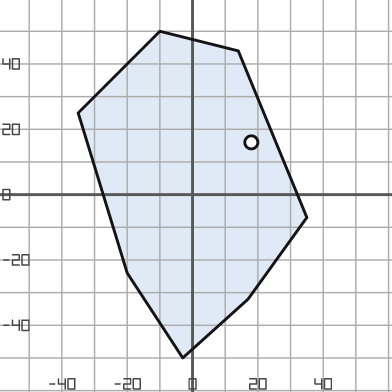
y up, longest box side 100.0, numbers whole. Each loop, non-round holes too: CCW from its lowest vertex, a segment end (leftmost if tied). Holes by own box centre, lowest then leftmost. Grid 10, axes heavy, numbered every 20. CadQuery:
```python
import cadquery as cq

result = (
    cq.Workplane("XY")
    .moveTo(-3.0, -50.0)
    .lineTo(17.0, -32.0)
    .lineTo(35.0, -7.0)
    .lineTo(14.0, 44.0)
    .lineTo(-10.0, 50.0)
    .lineTo(-35.0, 25.0)
    .lineTo(-20.0, -24.0)
    .close()
    .moveTo(18.0, 16.0)
    .circle(2.0)
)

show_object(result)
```